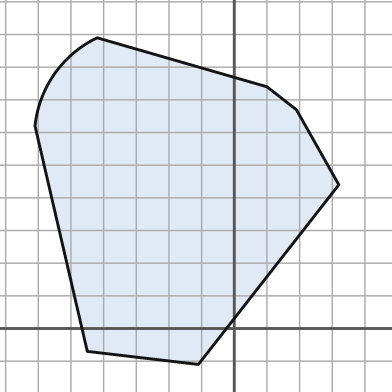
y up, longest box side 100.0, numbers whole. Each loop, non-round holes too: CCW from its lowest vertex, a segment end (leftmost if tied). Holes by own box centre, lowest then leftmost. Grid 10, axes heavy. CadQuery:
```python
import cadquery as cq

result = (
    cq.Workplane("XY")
    .moveTo(-11.0, -11.0)
    .lineTo(32.0, 44.0)
    .lineTo(19.0, 67.0)
    .lineTo(10.0, 74.0)
    .lineTo(-42.0, 89.0)
    .threePointArc((-55.0, 78.0), (-61.0, 62.0))
    .lineTo(-45.0, -7.0)
    .close()
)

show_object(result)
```